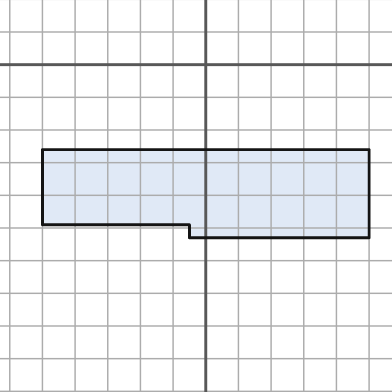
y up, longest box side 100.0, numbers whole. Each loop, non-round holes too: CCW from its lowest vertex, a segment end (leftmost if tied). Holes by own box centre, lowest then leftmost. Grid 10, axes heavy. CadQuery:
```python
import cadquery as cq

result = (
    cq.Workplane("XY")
    .moveTo(-5.0, -53.0)
    .lineTo(50.0, -53.0)
    .lineTo(50.0, -26.0)
    .lineTo(-50.0, -26.0)
    .lineTo(-50.0, -49.0)
    .lineTo(-5.0, -49.0)
    .close()
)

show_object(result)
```